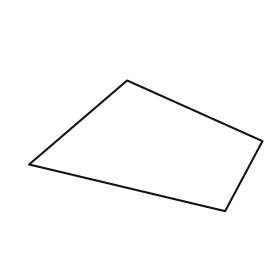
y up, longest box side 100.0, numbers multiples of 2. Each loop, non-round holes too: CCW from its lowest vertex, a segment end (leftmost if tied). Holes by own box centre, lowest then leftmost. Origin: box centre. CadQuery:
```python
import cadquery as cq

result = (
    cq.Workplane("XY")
    .moveTo(34.0, -28.0)
    .lineTo(50.0, 2.0)
    .lineTo(-8.0, 28.0)
    .lineTo(-50.0, -8.0)
    .close()
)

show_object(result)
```